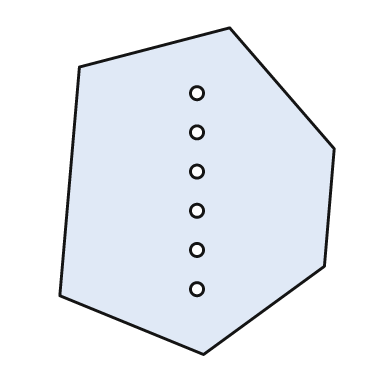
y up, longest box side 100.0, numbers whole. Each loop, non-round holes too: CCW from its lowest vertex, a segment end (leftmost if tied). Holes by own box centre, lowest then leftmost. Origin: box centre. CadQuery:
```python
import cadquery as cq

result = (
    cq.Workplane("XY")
    .moveTo(2.0, -50.0)
    .lineTo(39.0, -23.0)
    .lineTo(42.0, 13.0)
    .lineTo(10.0, 50.0)
    .lineTo(-36.0, 38.0)
    .lineTo(-42.0, -32.0)
    .close()
    .moveTo(0.0, -30.0)
    .circle(2.0)
    .moveTo(0.0, -18.0)
    .circle(2.0)
    .moveTo(0.0, -6.0)
    .circle(2.0)
    .moveTo(0.0, 6.0)
    .circle(2.0)
    .moveTo(0.0, 18.0)
    .circle(2.0)
    .moveTo(0.0, 30.0)
    .circle(2.0)
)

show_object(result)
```